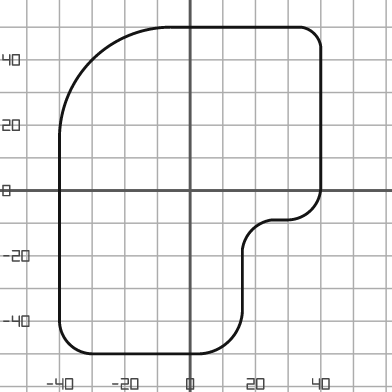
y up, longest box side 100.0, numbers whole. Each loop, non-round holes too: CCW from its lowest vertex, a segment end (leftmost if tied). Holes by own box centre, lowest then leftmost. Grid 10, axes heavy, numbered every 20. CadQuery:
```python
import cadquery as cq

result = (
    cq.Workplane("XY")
    .moveTo(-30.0, -50.0)
    .lineTo(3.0, -50.0)
    .threePointArc((12.0, -46.0), (16.0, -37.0))
    .lineTo(16.0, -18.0)
    .threePointArc((19.0, -12.0), (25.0, -9.0))
    .lineTo(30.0, -9.0)
    .threePointArc((37.0, -6.0), (40.0, 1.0))
    .lineTo(40.0, 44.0)
    .threePointArc((38.0, 48.0), (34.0, 50.0))
    .lineTo(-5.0, 50.0)
    .threePointArc((-30.0, 40.0), (-40.0, 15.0))
    .lineTo(-40.0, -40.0)
    .threePointArc((-37.0, -47.0), (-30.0, -50.0))
    .close()
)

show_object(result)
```